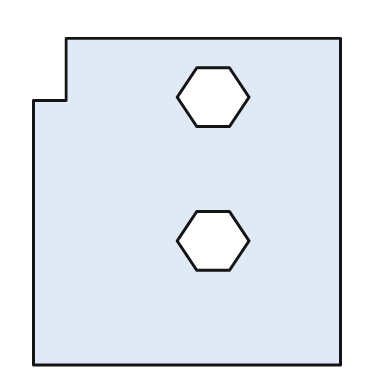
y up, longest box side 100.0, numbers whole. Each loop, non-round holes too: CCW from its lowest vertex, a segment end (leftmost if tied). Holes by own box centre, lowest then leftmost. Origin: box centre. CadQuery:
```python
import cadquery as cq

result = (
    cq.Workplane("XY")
    .moveTo(-47.0, -50.0)
    .lineTo(47.0, -50.0)
    .lineTo(47.0, 50.0)
    .lineTo(-37.0, 50.0)
    .lineTo(-37.0, 31.0)
    .lineTo(-47.0, 31.0)
    .close()
    .moveTo(3.0, -21.0)
    .lineTo(13.0, -21.0)
    .lineTo(19.0, -12.0)
    .lineTo(13.0, -3.0)
    .lineTo(3.0, -3.0)
    .lineTo(-3.0, -12.0)
    .close()
    .moveTo(3.0, 23.0)
    .lineTo(13.0, 23.0)
    .lineTo(19.0, 32.0)
    .lineTo(13.0, 41.0)
    .lineTo(3.0, 41.0)
    .lineTo(-3.0, 32.0)
    .close()
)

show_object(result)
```